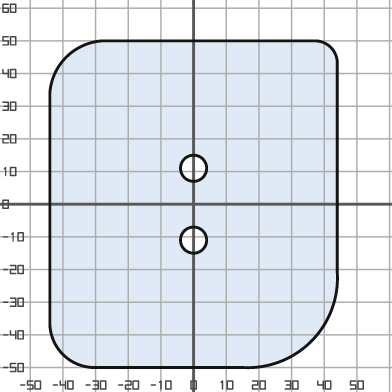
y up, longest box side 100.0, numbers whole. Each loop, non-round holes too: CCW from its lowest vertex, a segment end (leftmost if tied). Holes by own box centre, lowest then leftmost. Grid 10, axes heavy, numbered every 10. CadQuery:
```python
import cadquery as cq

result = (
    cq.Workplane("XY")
    .moveTo(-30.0, -50.0)
    .lineTo(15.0, -50.0)
    .threePointArc((36.0, -42.0), (44.0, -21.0))
    .lineTo(44.0, 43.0)
    .threePointArc((42.0, 48.0), (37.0, 50.0))
    .lineTo(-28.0, 50.0)
    .threePointArc((-39.0, 45.0), (-44.0, 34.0))
    .lineTo(-44.0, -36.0)
    .threePointArc((-40.0, -46.0), (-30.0, -50.0))
    .close()
    .moveTo(0.0, -11.0)
    .circle(4.0)
    .moveTo(0.0, 11.0)
    .circle(4.0)
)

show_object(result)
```